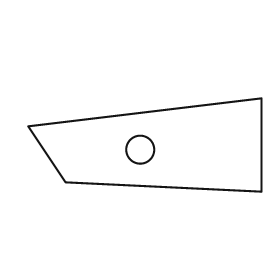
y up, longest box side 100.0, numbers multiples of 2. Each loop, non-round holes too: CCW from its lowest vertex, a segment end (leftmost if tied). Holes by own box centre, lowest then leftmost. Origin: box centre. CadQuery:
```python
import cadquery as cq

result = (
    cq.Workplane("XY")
    .moveTo(50.0, -20.0)
    .lineTo(50.0, 20.0)
    .lineTo(-50.0, 8.0)
    .lineTo(-34.0, -16.0)
    .close()
    .moveTo(-2.0, -2.0)
    .circle(6.0)
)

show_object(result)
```